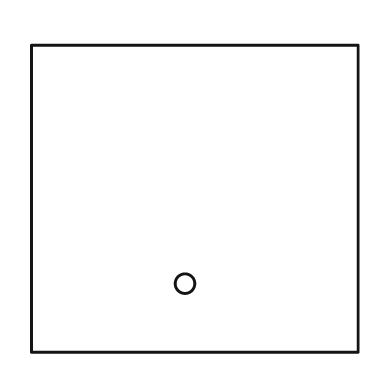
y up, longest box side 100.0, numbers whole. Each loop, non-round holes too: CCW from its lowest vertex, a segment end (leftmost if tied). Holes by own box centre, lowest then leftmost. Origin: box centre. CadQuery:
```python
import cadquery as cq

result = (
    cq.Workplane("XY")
    .moveTo(-50.0, -47.0)
    .lineTo(50.0, -47.0)
    .lineTo(50.0, 47.0)
    .lineTo(-50.0, 47.0)
    .close()
    .moveTo(-3.0, -26.0)
    .circle(3.0)
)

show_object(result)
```